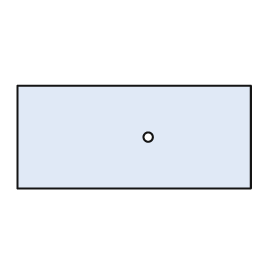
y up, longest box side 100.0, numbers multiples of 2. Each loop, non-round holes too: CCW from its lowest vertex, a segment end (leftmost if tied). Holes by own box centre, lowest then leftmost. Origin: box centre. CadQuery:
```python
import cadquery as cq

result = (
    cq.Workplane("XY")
    .moveTo(-50.0, -22.0)
    .lineTo(50.0, -22.0)
    .lineTo(50.0, 22.0)
    .lineTo(-50.0, 22.0)
    .close()
    .moveTo(6.0, 0.0)
    .circle(2.0)
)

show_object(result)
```